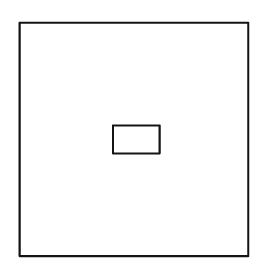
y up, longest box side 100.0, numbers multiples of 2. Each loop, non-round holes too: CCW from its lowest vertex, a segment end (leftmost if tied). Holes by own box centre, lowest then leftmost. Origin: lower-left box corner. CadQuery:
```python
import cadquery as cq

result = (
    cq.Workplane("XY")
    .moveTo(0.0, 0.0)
    .lineTo(98.0, 0.0)
    .lineTo(98.0, 100.0)
    .lineTo(0.0, 100.0)
    .close()
    .moveTo(40.0, 44.0)
    .lineTo(60.0, 44.0)
    .lineTo(60.0, 56.0)
    .lineTo(40.0, 56.0)
    .close()
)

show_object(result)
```